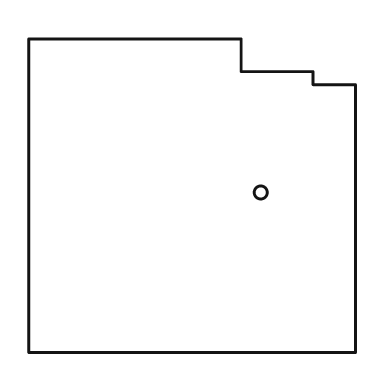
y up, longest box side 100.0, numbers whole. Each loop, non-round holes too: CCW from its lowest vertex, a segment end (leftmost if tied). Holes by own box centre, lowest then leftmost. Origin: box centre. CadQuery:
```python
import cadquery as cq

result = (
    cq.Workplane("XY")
    .moveTo(-50.0, -48.0)
    .lineTo(50.0, -48.0)
    .lineTo(50.0, 34.0)
    .lineTo(37.0, 34.0)
    .lineTo(37.0, 38.0)
    .lineTo(15.0, 38.0)
    .lineTo(15.0, 48.0)
    .lineTo(-50.0, 48.0)
    .close()
    .moveTo(21.0, 1.0)
    .circle(2.0)
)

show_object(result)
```